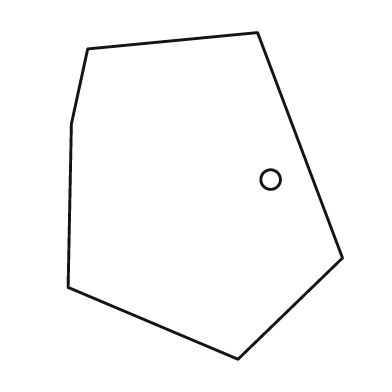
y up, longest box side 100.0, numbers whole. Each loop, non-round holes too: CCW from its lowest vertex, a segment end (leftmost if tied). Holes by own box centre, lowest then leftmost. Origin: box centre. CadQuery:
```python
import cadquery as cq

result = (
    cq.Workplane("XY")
    .moveTo(10.0, -50.0)
    .lineTo(42.0, -19.0)
    .lineTo(16.0, 50.0)
    .lineTo(-36.0, 45.0)
    .lineTo(-41.0, 22.0)
    .lineTo(-42.0, -28.0)
    .close()
    .moveTo(20.0, 5.0)
    .circle(3.0)
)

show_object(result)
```